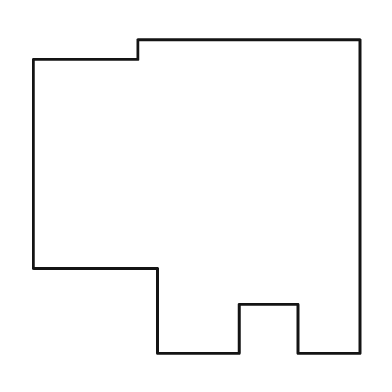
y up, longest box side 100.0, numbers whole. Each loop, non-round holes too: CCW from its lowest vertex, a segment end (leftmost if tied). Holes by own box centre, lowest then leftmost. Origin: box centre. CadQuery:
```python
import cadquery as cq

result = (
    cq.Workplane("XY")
    .moveTo(-12.0, -48.0)
    .lineTo(13.0, -48.0)
    .lineTo(13.0, -33.0)
    .lineTo(31.0, -33.0)
    .lineTo(31.0, -48.0)
    .lineTo(50.0, -48.0)
    .lineTo(50.0, 48.0)
    .lineTo(-18.0, 48.0)
    .lineTo(-18.0, 42.0)
    .lineTo(-50.0, 42.0)
    .lineTo(-50.0, -22.0)
    .lineTo(-12.0, -22.0)
    .close()
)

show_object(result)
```